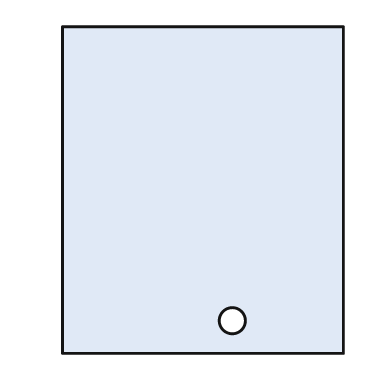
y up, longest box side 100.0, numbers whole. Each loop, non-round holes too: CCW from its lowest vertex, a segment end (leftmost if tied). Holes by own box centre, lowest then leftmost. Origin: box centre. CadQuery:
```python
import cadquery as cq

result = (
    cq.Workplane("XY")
    .moveTo(-43.0, -50.0)
    .lineTo(43.0, -50.0)
    .lineTo(43.0, 50.0)
    .lineTo(-43.0, 50.0)
    .close()
    .moveTo(9.0, -40.0)
    .circle(4.0)
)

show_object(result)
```